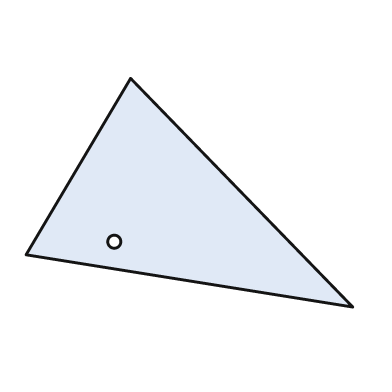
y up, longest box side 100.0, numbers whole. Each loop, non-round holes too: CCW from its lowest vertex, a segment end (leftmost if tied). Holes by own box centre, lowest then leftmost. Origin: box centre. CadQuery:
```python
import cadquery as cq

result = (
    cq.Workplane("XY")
    .moveTo(50.0, -35.0)
    .lineTo(-18.0, 35.0)
    .lineTo(-50.0, -19.0)
    .close()
    .moveTo(-23.0, -15.0)
    .circle(2.0)
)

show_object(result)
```